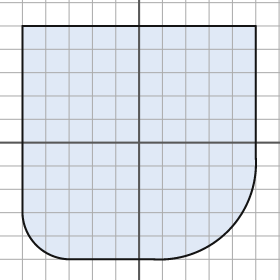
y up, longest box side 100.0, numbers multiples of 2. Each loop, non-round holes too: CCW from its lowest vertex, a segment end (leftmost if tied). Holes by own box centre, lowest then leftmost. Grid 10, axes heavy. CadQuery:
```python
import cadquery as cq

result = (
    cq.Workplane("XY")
    .moveTo(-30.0, -50.0)
    .lineTo(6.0, -50.0)
    .threePointArc((38.0, -38.0), (50.0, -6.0))
    .lineTo(50.0, 50.0)
    .lineTo(-50.0, 50.0)
    .lineTo(-50.0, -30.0)
    .threePointArc((-44.0, -44.0), (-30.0, -50.0))
    .close()
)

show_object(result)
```